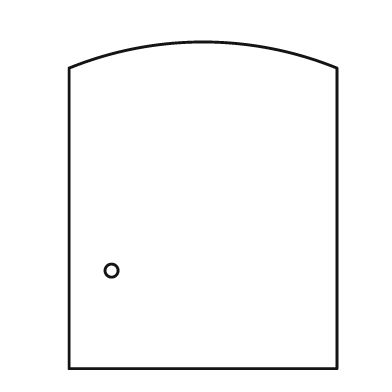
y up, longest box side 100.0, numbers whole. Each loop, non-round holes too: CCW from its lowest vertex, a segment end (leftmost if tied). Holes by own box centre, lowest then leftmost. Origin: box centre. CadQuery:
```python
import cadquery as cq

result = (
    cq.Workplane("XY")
    .moveTo(-41.0, -50.0)
    .lineTo(41.0, -50.0)
    .lineTo(41.0, 42.0)
    .threePointArc((0.0, 50.0), (-41.0, 42.0))
    .close()
    .moveTo(-28.0, -20.0)
    .circle(2.0)
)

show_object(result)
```